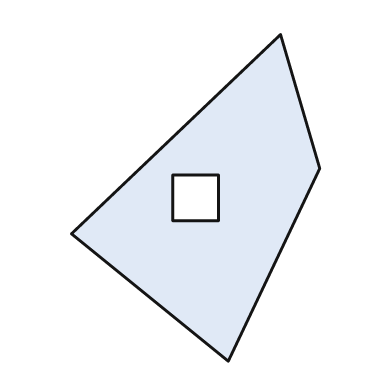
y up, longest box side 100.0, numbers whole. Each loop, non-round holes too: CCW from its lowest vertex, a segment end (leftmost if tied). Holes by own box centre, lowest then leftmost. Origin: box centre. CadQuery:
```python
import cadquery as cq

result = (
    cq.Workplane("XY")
    .moveTo(10.0, -50.0)
    .lineTo(38.0, 9.0)
    .lineTo(26.0, 50.0)
    .lineTo(-38.0, -11.0)
    .close()
    .moveTo(-7.0, -7.0)
    .lineTo(7.0, -7.0)
    .lineTo(7.0, 7.0)
    .lineTo(-7.0, 7.0)
    .close()
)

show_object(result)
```